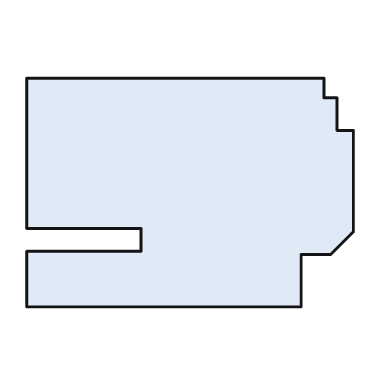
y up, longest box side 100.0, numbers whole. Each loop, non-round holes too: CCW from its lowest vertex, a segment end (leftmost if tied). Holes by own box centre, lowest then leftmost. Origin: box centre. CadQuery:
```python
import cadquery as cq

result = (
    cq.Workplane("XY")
    .moveTo(-50.0, -35.0)
    .lineTo(34.0, -35.0)
    .lineTo(34.0, -19.0)
    .lineTo(43.0, -19.0)
    .lineTo(50.0, -12.0)
    .lineTo(50.0, 19.0)
    .lineTo(45.0, 19.0)
    .lineTo(45.0, 29.0)
    .lineTo(41.0, 29.0)
    .lineTo(41.0, 35.0)
    .lineTo(-50.0, 35.0)
    .lineTo(-50.0, -11.0)
    .lineTo(-15.0, -11.0)
    .lineTo(-15.0, -18.0)
    .lineTo(-50.0, -18.0)
    .close()
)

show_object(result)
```